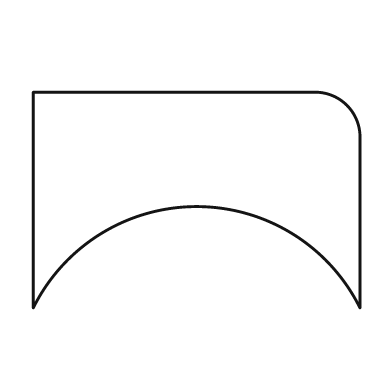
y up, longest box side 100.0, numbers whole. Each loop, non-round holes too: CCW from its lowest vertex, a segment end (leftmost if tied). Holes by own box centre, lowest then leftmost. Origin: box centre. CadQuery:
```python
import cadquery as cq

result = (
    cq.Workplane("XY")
    .moveTo(-50.0, -33.0)
    .threePointArc((0.0, -2.0), (50.0, -33.0))
    .lineTo(50.0, 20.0)
    .threePointArc((46.0, 29.0), (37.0, 33.0))
    .lineTo(-50.0, 33.0)
    .close()
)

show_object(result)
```